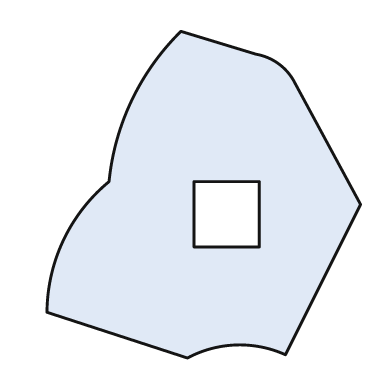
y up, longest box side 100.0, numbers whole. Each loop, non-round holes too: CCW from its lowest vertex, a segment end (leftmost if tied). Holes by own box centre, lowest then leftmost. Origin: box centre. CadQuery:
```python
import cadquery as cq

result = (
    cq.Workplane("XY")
    .moveTo(-5.0, -50.0)
    .threePointArc((10.0, -46.0), (25.0, -49.0))
    .lineTo(48.0, -3.0)
    .lineTo(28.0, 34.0)
    .threePointArc((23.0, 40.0), (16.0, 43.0))
    .lineTo(-7.0, 50.0)
    .threePointArc((-22.0, 29.0), (-29.0, 4.0))
    .threePointArc((-43.0, -14.0), (-48.0, -36.0))
    .close()
    .moveTo(-3.0, -16.0)
    .lineTo(17.0, -16.0)
    .lineTo(17.0, 4.0)
    .lineTo(-3.0, 4.0)
    .close()
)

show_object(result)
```